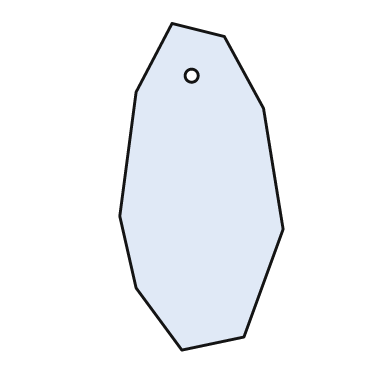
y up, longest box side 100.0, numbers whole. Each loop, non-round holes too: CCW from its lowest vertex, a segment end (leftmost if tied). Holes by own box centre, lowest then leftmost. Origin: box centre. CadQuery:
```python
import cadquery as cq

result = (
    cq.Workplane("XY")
    .moveTo(-6.0, -50.0)
    .lineTo(13.0, -46.0)
    .lineTo(25.0, -13.0)
    .lineTo(19.0, 24.0)
    .lineTo(7.0, 46.0)
    .lineTo(-9.0, 50.0)
    .lineTo(-20.0, 29.0)
    .lineTo(-25.0, -9.0)
    .lineTo(-20.0, -31.0)
    .close()
    .moveTo(-3.0, 34.0)
    .circle(2.0)
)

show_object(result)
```